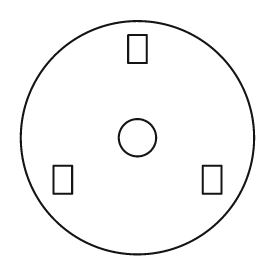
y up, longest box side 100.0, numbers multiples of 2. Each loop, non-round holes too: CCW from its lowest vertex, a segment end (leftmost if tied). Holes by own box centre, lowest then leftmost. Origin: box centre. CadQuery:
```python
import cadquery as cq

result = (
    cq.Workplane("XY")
    .moveTo(0.0, 0.0)
    .circle(50.0)
    .moveTo(-36.0, -24.0)
    .lineTo(-28.0, -24.0)
    .lineTo(-28.0, -12.0)
    .lineTo(-36.0, -12.0)
    .close()
    .moveTo(28.0, -24.0)
    .lineTo(36.0, -24.0)
    .lineTo(36.0, -12.0)
    .lineTo(28.0, -12.0)
    .close()
    .moveTo(0.0, 0.0)
    .circle(8.0)
    .moveTo(-4.0, 32.0)
    .lineTo(4.0, 32.0)
    .lineTo(4.0, 44.0)
    .lineTo(-4.0, 44.0)
    .close()
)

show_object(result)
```